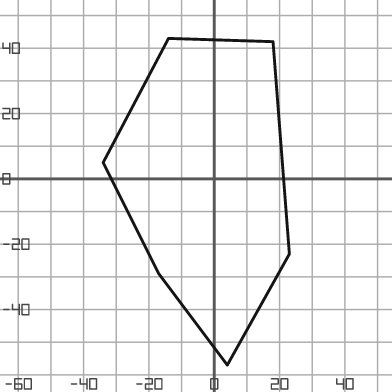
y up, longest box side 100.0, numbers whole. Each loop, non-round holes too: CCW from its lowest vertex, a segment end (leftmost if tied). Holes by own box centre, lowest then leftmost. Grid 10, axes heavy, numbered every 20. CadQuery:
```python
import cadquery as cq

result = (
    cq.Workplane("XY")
    .moveTo(4.0, -57.0)
    .lineTo(23.0, -23.0)
    .lineTo(18.0, 42.0)
    .lineTo(-14.0, 43.0)
    .lineTo(-34.0, 5.0)
    .lineTo(-17.0, -29.0)
    .close()
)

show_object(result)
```